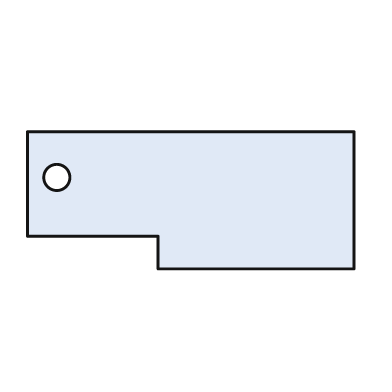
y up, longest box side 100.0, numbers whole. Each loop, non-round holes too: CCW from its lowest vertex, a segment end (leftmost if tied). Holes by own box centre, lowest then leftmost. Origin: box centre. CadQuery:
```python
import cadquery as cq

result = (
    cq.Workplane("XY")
    .moveTo(-10.0, -21.0)
    .lineTo(50.0, -21.0)
    .lineTo(50.0, 21.0)
    .lineTo(-50.0, 21.0)
    .lineTo(-50.0, -11.0)
    .lineTo(-10.0, -11.0)
    .close()
    .moveTo(-41.0, 7.0)
    .circle(4.0)
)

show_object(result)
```